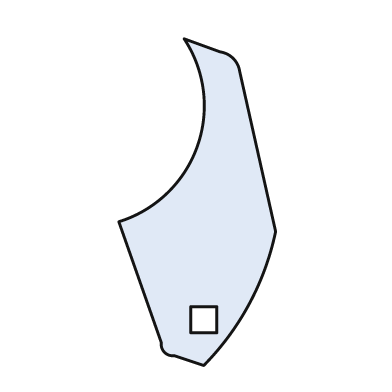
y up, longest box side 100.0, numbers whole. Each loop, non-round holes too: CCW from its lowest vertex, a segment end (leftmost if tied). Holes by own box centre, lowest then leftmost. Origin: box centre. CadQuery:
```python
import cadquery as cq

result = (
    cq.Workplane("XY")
    .moveTo(2.0, -50.0)
    .threePointArc((16.0, -31.0), (24.0, -9.0))
    .lineTo(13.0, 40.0)
    .threePointArc((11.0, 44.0), (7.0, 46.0))
    .lineTo(-4.0, 50.0)
    .threePointArc((0.0, 17.0), (-24.0, -6.0))
    .lineTo(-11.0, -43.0)
    .threePointArc((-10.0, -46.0), (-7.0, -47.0))
    .close()
    .moveTo(-2.0, -40.0)
    .lineTo(6.0, -40.0)
    .lineTo(6.0, -32.0)
    .lineTo(-2.0, -32.0)
    .close()
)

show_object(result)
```